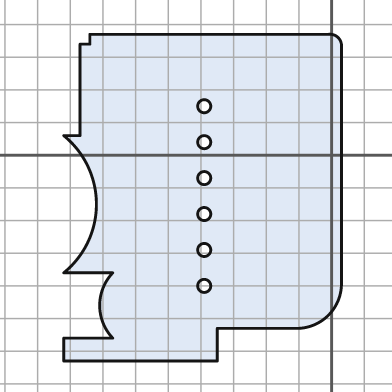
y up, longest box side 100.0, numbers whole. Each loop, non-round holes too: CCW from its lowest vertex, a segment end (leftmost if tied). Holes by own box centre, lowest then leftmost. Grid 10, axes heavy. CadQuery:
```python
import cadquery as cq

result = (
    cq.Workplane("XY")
    .moveTo(-82.0, -63.0)
    .lineTo(-35.0, -63.0)
    .lineTo(-35.0, -53.0)
    .lineTo(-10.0, -53.0)
    .threePointArc((-1.0, -49.0), (3.0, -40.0))
    .lineTo(3.0, 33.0)
    .threePointArc((2.0, 36.0), (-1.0, 37.0))
    .lineTo(-74.0, 37.0)
    .lineTo(-74.0, 34.0)
    .lineTo(-77.0, 34.0)
    .lineTo(-77.0, 6.0)
    .lineTo(-82.0, 6.0)
    .threePointArc((-72.0, -15.0), (-82.0, -36.0))
    .lineTo(-67.0, -36.0)
    .threePointArc((-71.0, -46.0), (-67.0, -56.0))
    .lineTo(-82.0, -56.0)
    .close()
    .moveTo(-39.0, -40.0)
    .circle(2.0)
    .moveTo(-39.0, -29.0)
    .circle(2.0)
    .moveTo(-39.0, -18.0)
    .circle(2.0)
    .moveTo(-39.0, -7.0)
    .circle(2.0)
    .moveTo(-39.0, 4.0)
    .circle(2.0)
    .moveTo(-39.0, 15.0)
    .circle(2.0)
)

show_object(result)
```